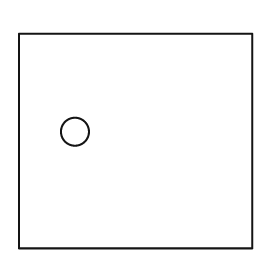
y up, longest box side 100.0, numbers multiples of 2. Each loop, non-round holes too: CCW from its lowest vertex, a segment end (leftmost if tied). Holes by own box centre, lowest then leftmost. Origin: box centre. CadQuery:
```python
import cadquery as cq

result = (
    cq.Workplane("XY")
    .moveTo(-50.0, -46.0)
    .lineTo(50.0, -46.0)
    .lineTo(50.0, 46.0)
    .lineTo(-50.0, 46.0)
    .close()
    .moveTo(-26.0, 4.0)
    .circle(6.0)
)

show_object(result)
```